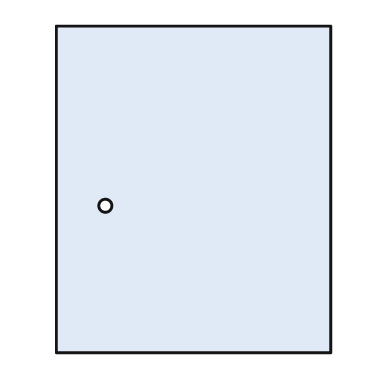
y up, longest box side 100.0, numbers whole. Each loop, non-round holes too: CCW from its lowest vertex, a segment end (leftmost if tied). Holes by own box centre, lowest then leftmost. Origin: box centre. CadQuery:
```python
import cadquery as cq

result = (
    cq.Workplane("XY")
    .moveTo(-42.0, -50.0)
    .lineTo(42.0, -50.0)
    .lineTo(42.0, 50.0)
    .lineTo(-42.0, 50.0)
    .close()
    .moveTo(-27.0, -5.0)
    .circle(2.0)
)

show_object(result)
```